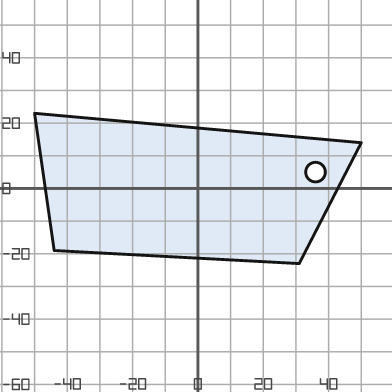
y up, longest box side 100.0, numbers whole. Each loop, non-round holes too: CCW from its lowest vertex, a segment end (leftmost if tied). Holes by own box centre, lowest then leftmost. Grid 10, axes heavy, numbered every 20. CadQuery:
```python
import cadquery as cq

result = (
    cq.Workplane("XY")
    .moveTo(31.0, -23.0)
    .lineTo(50.0, 14.0)
    .lineTo(-50.0, 23.0)
    .lineTo(-44.0, -19.0)
    .close()
    .moveTo(36.0, 5.0)
    .circle(3.0)
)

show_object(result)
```